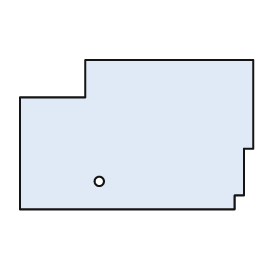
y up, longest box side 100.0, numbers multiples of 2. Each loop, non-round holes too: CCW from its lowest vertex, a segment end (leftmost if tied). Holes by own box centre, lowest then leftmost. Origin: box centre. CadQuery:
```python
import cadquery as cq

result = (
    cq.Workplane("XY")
    .moveTo(-50.0, -32.0)
    .lineTo(42.0, -32.0)
    .lineTo(42.0, -26.0)
    .lineTo(46.0, -26.0)
    .lineTo(46.0, -6.0)
    .lineTo(50.0, -6.0)
    .lineTo(50.0, 32.0)
    .lineTo(-22.0, 32.0)
    .lineTo(-22.0, 16.0)
    .lineTo(-50.0, 16.0)
    .close()
    .moveTo(-16.0, -20.0)
    .circle(2.0)
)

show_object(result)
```